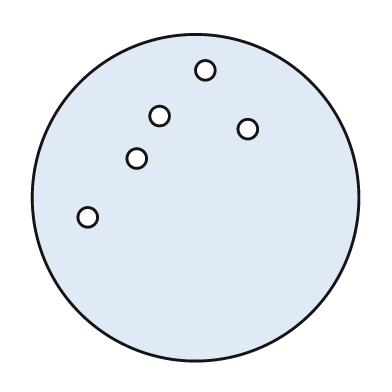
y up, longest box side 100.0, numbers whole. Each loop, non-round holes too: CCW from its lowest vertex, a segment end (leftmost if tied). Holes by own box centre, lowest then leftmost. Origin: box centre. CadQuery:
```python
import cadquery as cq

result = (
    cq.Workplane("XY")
    .moveTo(0.0, 0.0)
    .circle(50.0)
    .moveTo(-33.0, -6.0)
    .circle(3.0)
    .moveTo(-18.0, 12.0)
    .circle(3.0)
    .moveTo(16.0, 21.0)
    .circle(3.0)
    .moveTo(-11.0, 25.0)
    .circle(3.0)
    .moveTo(3.0, 39.0)
    .circle(3.0)
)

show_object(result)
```